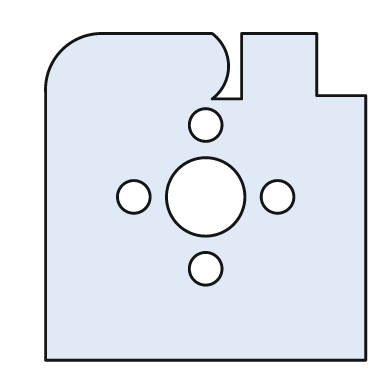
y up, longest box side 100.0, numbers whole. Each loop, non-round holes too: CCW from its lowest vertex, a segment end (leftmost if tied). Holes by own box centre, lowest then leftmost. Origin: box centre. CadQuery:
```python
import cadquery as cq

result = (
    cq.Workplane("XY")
    .moveTo(-49.0, -50.0)
    .lineTo(49.0, -50.0)
    .lineTo(49.0, 31.0)
    .lineTo(34.0, 31.0)
    .lineTo(34.0, 50.0)
    .lineTo(11.0, 50.0)
    .lineTo(11.0, 30.0)
    .lineTo(2.0, 30.0)
    .threePointArc((7.0, 40.0), (2.0, 50.0))
    .lineTo(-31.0, 50.0)
    .threePointArc((-44.0, 45.0), (-49.0, 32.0))
    .close()
    .moveTo(0.0, -22.0)
    .circle(5.0)
    .moveTo(-22.0, 0.0)
    .circle(5.0)
    .moveTo(0.0, 0.0)
    .circle(12.0)
    .moveTo(22.0, 0.0)
    .circle(5.0)
    .moveTo(0.0, 22.0)
    .circle(5.0)
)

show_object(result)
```